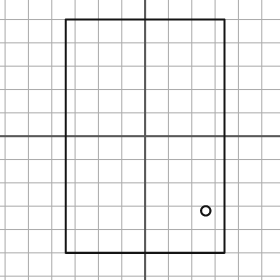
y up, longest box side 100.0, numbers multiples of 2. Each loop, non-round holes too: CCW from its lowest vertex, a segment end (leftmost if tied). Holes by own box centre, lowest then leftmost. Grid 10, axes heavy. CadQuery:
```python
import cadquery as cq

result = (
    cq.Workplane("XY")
    .moveTo(-34.0, -50.0)
    .lineTo(34.0, -50.0)
    .lineTo(34.0, 50.0)
    .lineTo(-34.0, 50.0)
    .close()
    .moveTo(26.0, -32.0)
    .circle(2.0)
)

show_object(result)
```